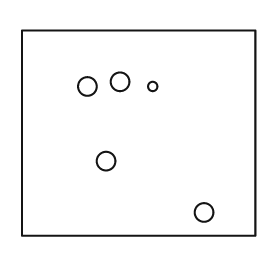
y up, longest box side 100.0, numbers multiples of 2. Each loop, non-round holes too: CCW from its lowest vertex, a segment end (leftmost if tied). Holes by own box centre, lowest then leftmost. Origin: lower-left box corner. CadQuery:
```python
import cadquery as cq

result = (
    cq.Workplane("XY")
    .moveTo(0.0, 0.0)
    .lineTo(100.0, 0.0)
    .lineTo(100.0, 88.0)
    .lineTo(0.0, 88.0)
    .close()
    .moveTo(78.0, 10.0)
    .circle(4.0)
    .moveTo(36.0, 32.0)
    .circle(4.0)
    .moveTo(28.0, 64.0)
    .circle(4.0)
    .moveTo(56.0, 64.0)
    .circle(2.0)
    .moveTo(42.0, 66.0)
    .circle(4.0)
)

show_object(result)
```